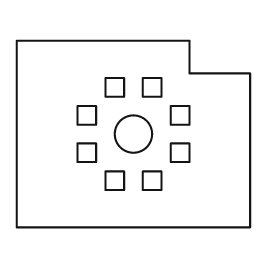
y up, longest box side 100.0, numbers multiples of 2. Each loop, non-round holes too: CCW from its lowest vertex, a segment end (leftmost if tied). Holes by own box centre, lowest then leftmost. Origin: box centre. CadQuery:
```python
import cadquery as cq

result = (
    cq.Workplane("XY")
    .moveTo(-50.0, -40.0)
    .lineTo(50.0, -40.0)
    .lineTo(50.0, 26.0)
    .lineTo(24.0, 26.0)
    .lineTo(24.0, 40.0)
    .lineTo(-50.0, 40.0)
    .close()
    .moveTo(-12.0, -24.0)
    .lineTo(-4.0, -24.0)
    .lineTo(-4.0, -16.0)
    .lineTo(-12.0, -16.0)
    .close()
    .moveTo(4.0, -24.0)
    .lineTo(12.0, -24.0)
    .lineTo(12.0, -16.0)
    .lineTo(4.0, -16.0)
    .close()
    .moveTo(-24.0, -12.0)
    .lineTo(-16.0, -12.0)
    .lineTo(-16.0, -4.0)
    .lineTo(-24.0, -4.0)
    .close()
    .moveTo(16.0, -12.0)
    .lineTo(24.0, -12.0)
    .lineTo(24.0, -4.0)
    .lineTo(16.0, -4.0)
    .close()
    .moveTo(0.0, 0.0)
    .circle(8.0)
    .moveTo(-24.0, 4.0)
    .lineTo(-16.0, 4.0)
    .lineTo(-16.0, 12.0)
    .lineTo(-24.0, 12.0)
    .close()
    .moveTo(16.0, 4.0)
    .lineTo(24.0, 4.0)
    .lineTo(24.0, 12.0)
    .lineTo(16.0, 12.0)
    .close()
    .moveTo(-12.0, 16.0)
    .lineTo(-4.0, 16.0)
    .lineTo(-4.0, 24.0)
    .lineTo(-12.0, 24.0)
    .close()
    .moveTo(4.0, 16.0)
    .lineTo(12.0, 16.0)
    .lineTo(12.0, 24.0)
    .lineTo(4.0, 24.0)
    .close()
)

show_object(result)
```